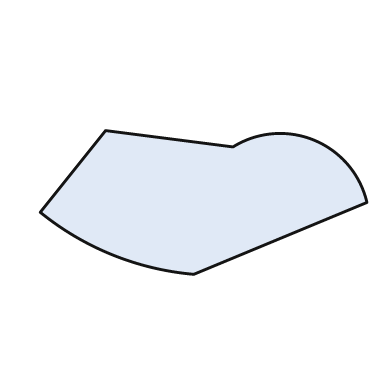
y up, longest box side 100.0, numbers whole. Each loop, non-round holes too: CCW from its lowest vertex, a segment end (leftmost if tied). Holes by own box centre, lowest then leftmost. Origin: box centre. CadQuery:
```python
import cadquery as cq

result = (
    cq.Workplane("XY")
    .moveTo(-3.0, -22.0)
    .lineTo(50.0, 0.0)
    .threePointArc((34.0, 19.0), (9.0, 17.0))
    .lineTo(-30.0, 22.0)
    .lineTo(-50.0, -3.0)
    .threePointArc((-28.0, -16.0), (-3.0, -22.0))
    .close()
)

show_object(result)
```